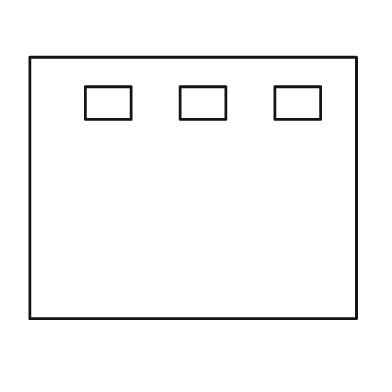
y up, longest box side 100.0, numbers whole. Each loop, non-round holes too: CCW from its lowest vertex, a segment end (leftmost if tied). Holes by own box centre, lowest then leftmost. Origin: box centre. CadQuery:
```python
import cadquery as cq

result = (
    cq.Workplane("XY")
    .moveTo(-50.0, -40.0)
    .lineTo(50.0, -40.0)
    .lineTo(50.0, 40.0)
    .lineTo(-50.0, 40.0)
    .close()
    .moveTo(-33.0, 21.0)
    .lineTo(-19.0, 21.0)
    .lineTo(-19.0, 31.0)
    .lineTo(-33.0, 31.0)
    .close()
    .moveTo(-4.0, 21.0)
    .lineTo(10.0, 21.0)
    .lineTo(10.0, 31.0)
    .lineTo(-4.0, 31.0)
    .close()
    .moveTo(25.0, 21.0)
    .lineTo(39.0, 21.0)
    .lineTo(39.0, 31.0)
    .lineTo(25.0, 31.0)
    .close()
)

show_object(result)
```